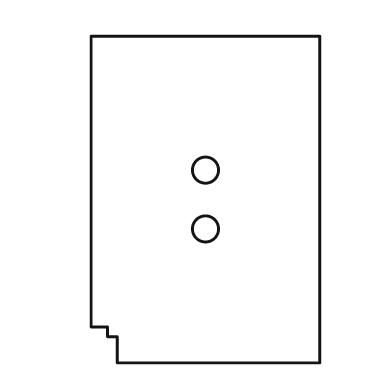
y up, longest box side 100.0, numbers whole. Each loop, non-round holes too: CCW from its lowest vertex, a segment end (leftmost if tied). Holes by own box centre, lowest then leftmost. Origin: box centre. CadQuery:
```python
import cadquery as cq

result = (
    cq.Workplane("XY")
    .moveTo(-27.0, -50.0)
    .lineTo(35.0, -50.0)
    .lineTo(35.0, 50.0)
    .lineTo(-35.0, 50.0)
    .lineTo(-35.0, -39.0)
    .lineTo(-30.0, -39.0)
    .lineTo(-30.0, -42.0)
    .lineTo(-27.0, -42.0)
    .close()
    .moveTo(0.0, -9.0)
    .circle(4.0)
    .moveTo(0.0, 9.0)
    .circle(4.0)
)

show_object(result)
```